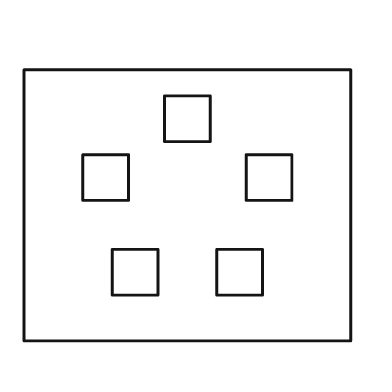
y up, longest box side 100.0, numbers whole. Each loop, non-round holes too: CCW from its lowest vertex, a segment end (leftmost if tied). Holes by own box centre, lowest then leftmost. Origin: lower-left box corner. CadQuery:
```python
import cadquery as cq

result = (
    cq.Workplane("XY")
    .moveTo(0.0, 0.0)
    .lineTo(100.0, 0.0)
    .lineTo(100.0, 83.0)
    .lineTo(0.0, 83.0)
    .close()
    .moveTo(27.0, 14.0)
    .lineTo(41.0, 14.0)
    .lineTo(41.0, 28.0)
    .lineTo(27.0, 28.0)
    .close()
    .moveTo(59.0, 14.0)
    .lineTo(73.0, 14.0)
    .lineTo(73.0, 28.0)
    .lineTo(59.0, 28.0)
    .close()
    .moveTo(18.0, 43.0)
    .lineTo(32.0, 43.0)
    .lineTo(32.0, 57.0)
    .lineTo(18.0, 57.0)
    .close()
    .moveTo(68.0, 43.0)
    .lineTo(82.0, 43.0)
    .lineTo(82.0, 57.0)
    .lineTo(68.0, 57.0)
    .close()
    .moveTo(43.0, 61.0)
    .lineTo(57.0, 61.0)
    .lineTo(57.0, 75.0)
    .lineTo(43.0, 75.0)
    .close()
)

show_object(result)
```